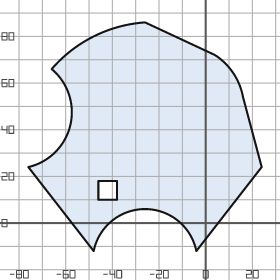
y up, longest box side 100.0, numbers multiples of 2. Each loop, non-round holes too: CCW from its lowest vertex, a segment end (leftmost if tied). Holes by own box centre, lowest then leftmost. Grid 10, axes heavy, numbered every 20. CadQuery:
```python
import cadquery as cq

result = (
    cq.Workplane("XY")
    .moveTo(-48.0, -12.0)
    .threePointArc((-26.0, 6.0), (-4.0, -12.0))
    .lineTo(24.0, 24.0)
    .lineTo(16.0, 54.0)
    .threePointArc((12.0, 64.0), (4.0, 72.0))
    .lineTo(-26.0, 86.0)
    .threePointArc((-48.0, 80.0), (-66.0, 66.0))
    .threePointArc((-58.0, 42.0), (-76.0, 24.0))
    .close()
    .moveTo(-46.0, 10.0)
    .lineTo(-38.0, 10.0)
    .lineTo(-38.0, 18.0)
    .lineTo(-46.0, 18.0)
    .close()
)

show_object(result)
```